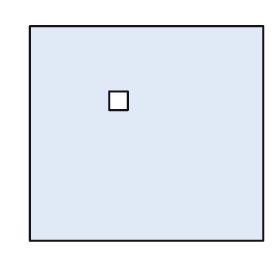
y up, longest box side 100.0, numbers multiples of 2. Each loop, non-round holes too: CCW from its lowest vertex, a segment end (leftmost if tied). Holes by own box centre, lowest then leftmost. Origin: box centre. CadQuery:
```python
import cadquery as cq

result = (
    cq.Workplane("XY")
    .moveTo(-50.0, -46.0)
    .lineTo(50.0, -46.0)
    .lineTo(50.0, 46.0)
    .lineTo(-50.0, 46.0)
    .close()
    .moveTo(-16.0, 10.0)
    .lineTo(-8.0, 10.0)
    .lineTo(-8.0, 18.0)
    .lineTo(-16.0, 18.0)
    .close()
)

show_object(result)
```